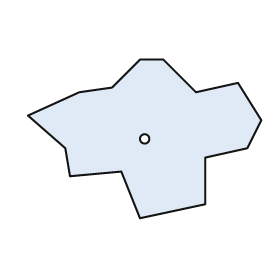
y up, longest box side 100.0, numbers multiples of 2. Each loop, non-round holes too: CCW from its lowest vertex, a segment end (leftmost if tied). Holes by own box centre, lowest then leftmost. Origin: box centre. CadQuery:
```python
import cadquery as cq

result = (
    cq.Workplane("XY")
    .moveTo(-2.0, -34.0)
    .lineTo(26.0, -28.0)
    .lineTo(26.0, -8.0)
    .lineTo(44.0, -4.0)
    .lineTo(50.0, 8.0)
    .lineTo(40.0, 24.0)
    .lineTo(22.0, 20.0)
    .lineTo(8.0, 34.0)
    .lineTo(-2.0, 34.0)
    .lineTo(-14.0, 22.0)
    .lineTo(-28.0, 20.0)
    .lineTo(-50.0, 10.0)
    .lineTo(-34.0, -4.0)
    .lineTo(-32.0, -16.0)
    .lineTo(-10.0, -14.0)
    .close()
    .moveTo(0.0, 0.0)
    .circle(2.0)
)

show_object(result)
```